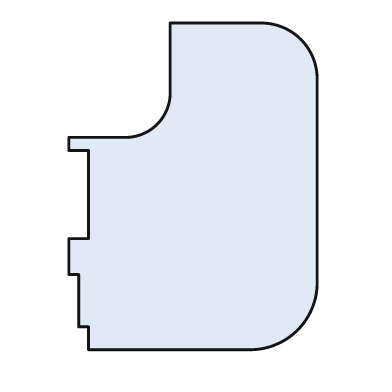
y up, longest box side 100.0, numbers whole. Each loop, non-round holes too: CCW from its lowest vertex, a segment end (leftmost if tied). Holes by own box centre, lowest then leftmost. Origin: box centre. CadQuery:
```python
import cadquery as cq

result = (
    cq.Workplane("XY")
    .moveTo(-32.0, -50.0)
    .lineTo(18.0, -50.0)
    .threePointArc((32.0, -44.0), (38.0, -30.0))
    .lineTo(38.0, 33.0)
    .threePointArc((33.0, 45.0), (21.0, 50.0))
    .lineTo(-7.0, 50.0)
    .lineTo(-7.0, 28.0)
    .threePointArc((-11.0, 19.0), (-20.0, 15.0))
    .lineTo(-38.0, 15.0)
    .lineTo(-38.0, 11.0)
    .lineTo(-32.0, 11.0)
    .lineTo(-32.0, -16.0)
    .lineTo(-38.0, -16.0)
    .lineTo(-38.0, -27.0)
    .lineTo(-35.0, -27.0)
    .lineTo(-35.0, -43.0)
    .lineTo(-32.0, -43.0)
    .close()
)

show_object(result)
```